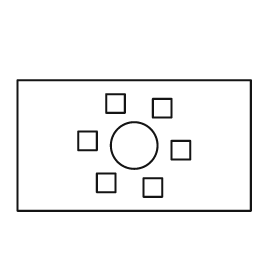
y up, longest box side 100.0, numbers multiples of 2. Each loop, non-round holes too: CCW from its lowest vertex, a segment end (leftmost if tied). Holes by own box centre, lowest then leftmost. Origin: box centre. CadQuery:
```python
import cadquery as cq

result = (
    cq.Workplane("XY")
    .moveTo(-50.0, -28.0)
    .lineTo(50.0, -28.0)
    .lineTo(50.0, 28.0)
    .lineTo(-50.0, 28.0)
    .close()
    .moveTo(4.0, -22.0)
    .lineTo(12.0, -22.0)
    .lineTo(12.0, -14.0)
    .lineTo(4.0, -14.0)
    .close()
    .moveTo(-16.0, -20.0)
    .lineTo(-8.0, -20.0)
    .lineTo(-8.0, -12.0)
    .lineTo(-16.0, -12.0)
    .close()
    .moveTo(16.0, -6.0)
    .lineTo(24.0, -6.0)
    .lineTo(24.0, 2.0)
    .lineTo(16.0, 2.0)
    .close()
    .moveTo(0.0, 0.0)
    .circle(10.0)
    .moveTo(-24.0, -2.0)
    .lineTo(-16.0, -2.0)
    .lineTo(-16.0, 6.0)
    .lineTo(-24.0, 6.0)
    .close()
    .moveTo(8.0, 12.0)
    .lineTo(16.0, 12.0)
    .lineTo(16.0, 20.0)
    .lineTo(8.0, 20.0)
    .close()
    .moveTo(-12.0, 14.0)
    .lineTo(-4.0, 14.0)
    .lineTo(-4.0, 22.0)
    .lineTo(-12.0, 22.0)
    .close()
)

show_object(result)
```